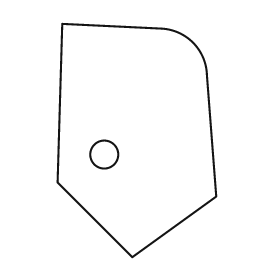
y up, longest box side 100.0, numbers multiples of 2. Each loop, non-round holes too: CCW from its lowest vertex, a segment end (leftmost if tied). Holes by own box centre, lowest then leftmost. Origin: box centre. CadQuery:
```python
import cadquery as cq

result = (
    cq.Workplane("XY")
    .moveTo(-2.0, -50.0)
    .lineTo(34.0, -24.0)
    .lineTo(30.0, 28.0)
    .threePointArc((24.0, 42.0), (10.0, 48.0))
    .lineTo(-32.0, 50.0)
    .lineTo(-34.0, -18.0)
    .close()
    .moveTo(-14.0, -6.0)
    .circle(6.0)
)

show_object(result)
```